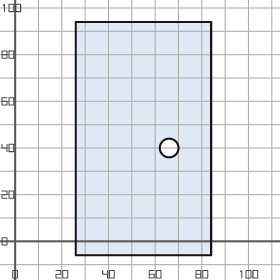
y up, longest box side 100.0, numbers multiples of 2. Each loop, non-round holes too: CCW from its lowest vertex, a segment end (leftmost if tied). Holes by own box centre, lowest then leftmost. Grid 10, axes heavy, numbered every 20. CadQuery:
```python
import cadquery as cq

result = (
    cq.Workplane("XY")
    .moveTo(26.0, -6.0)
    .lineTo(84.0, -6.0)
    .lineTo(84.0, 94.0)
    .lineTo(26.0, 94.0)
    .close()
    .moveTo(66.0, 40.0)
    .circle(4.0)
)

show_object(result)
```